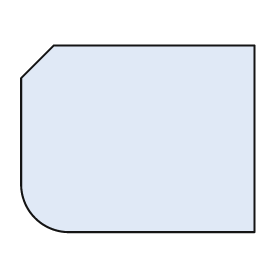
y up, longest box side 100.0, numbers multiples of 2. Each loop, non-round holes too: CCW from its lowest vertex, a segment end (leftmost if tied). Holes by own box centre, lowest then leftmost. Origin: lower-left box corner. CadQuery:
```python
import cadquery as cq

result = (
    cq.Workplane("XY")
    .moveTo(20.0, 0.0)
    .lineTo(100.0, 0.0)
    .lineTo(100.0, 80.0)
    .lineTo(14.0, 80.0)
    .lineTo(0.0, 66.0)
    .lineTo(0.0, 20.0)
    .threePointArc((6.0, 6.0), (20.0, 0.0))
    .close()
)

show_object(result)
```